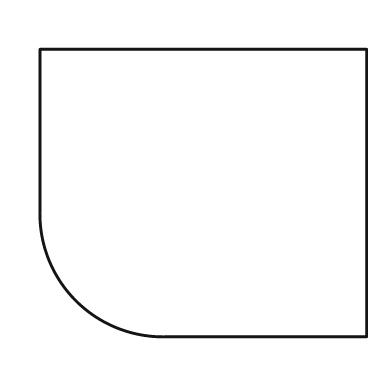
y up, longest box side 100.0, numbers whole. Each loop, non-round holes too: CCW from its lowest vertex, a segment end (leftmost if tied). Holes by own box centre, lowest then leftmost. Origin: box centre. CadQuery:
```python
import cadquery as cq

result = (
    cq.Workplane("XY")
    .moveTo(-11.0, -44.0)
    .lineTo(50.0, -44.0)
    .lineTo(50.0, 44.0)
    .lineTo(-50.0, 44.0)
    .lineTo(-50.0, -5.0)
    .threePointArc((-39.0, -33.0), (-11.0, -44.0))
    .close()
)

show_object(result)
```